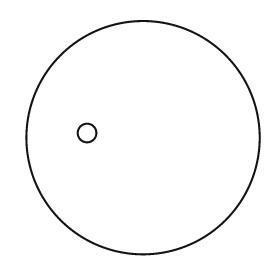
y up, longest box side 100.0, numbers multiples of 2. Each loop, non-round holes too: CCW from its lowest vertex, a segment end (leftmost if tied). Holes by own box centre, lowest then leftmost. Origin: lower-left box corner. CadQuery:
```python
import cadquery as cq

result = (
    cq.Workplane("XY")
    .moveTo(50.0, 50.0)
    .circle(50.0)
    .moveTo(26.0, 52.0)
    .circle(4.0)
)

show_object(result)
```